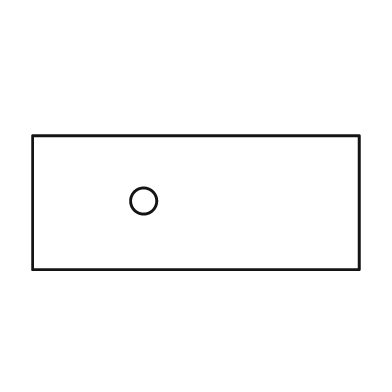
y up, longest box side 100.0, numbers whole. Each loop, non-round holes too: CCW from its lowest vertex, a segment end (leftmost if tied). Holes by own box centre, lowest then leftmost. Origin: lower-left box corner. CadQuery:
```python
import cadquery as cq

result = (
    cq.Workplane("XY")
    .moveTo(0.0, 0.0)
    .lineTo(100.0, 0.0)
    .lineTo(100.0, 41.0)
    .lineTo(0.0, 41.0)
    .close()
    .moveTo(34.0, 21.0)
    .circle(4.0)
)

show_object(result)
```